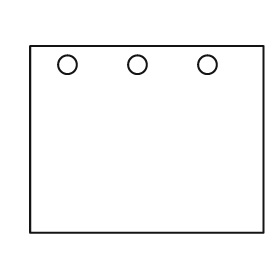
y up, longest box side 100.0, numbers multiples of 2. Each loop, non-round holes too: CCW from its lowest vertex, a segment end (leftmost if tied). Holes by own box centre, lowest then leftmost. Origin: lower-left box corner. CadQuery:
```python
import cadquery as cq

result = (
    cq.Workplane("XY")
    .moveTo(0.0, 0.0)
    .lineTo(100.0, 0.0)
    .lineTo(100.0, 80.0)
    .lineTo(0.0, 80.0)
    .close()
    .moveTo(16.0, 72.0)
    .circle(4.0)
    .moveTo(46.0, 72.0)
    .circle(4.0)
    .moveTo(76.0, 72.0)
    .circle(4.0)
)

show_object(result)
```